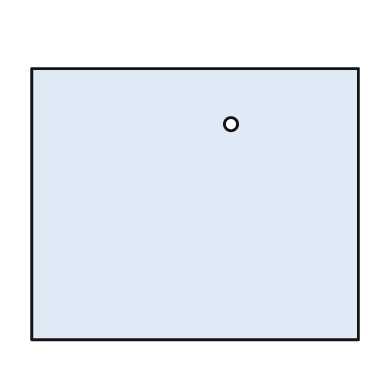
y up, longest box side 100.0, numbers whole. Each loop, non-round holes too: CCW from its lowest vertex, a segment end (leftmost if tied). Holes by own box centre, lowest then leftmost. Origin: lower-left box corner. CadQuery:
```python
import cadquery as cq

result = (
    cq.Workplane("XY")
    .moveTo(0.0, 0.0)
    .lineTo(100.0, 0.0)
    .lineTo(100.0, 83.0)
    .lineTo(0.0, 83.0)
    .close()
    .moveTo(61.0, 66.0)
    .circle(2.0)
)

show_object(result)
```